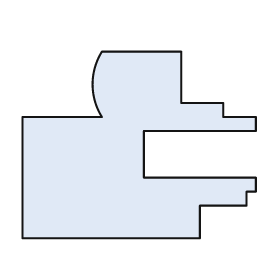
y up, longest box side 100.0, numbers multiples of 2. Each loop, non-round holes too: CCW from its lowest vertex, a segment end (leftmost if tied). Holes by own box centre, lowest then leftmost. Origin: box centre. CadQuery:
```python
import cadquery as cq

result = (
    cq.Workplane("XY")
    .moveTo(-50.0, -40.0)
    .lineTo(26.0, -40.0)
    .lineTo(26.0, -26.0)
    .lineTo(46.0, -26.0)
    .lineTo(46.0, -20.0)
    .lineTo(50.0, -20.0)
    .lineTo(50.0, -14.0)
    .lineTo(2.0, -14.0)
    .lineTo(2.0, 6.0)
    .lineTo(50.0, 6.0)
    .lineTo(50.0, 12.0)
    .lineTo(36.0, 12.0)
    .lineTo(36.0, 18.0)
    .lineTo(18.0, 18.0)
    .lineTo(18.0, 40.0)
    .lineTo(-16.0, 40.0)
    .threePointArc((-20.0, 26.0), (-16.0, 12.0))
    .lineTo(-50.0, 12.0)
    .close()
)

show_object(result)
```